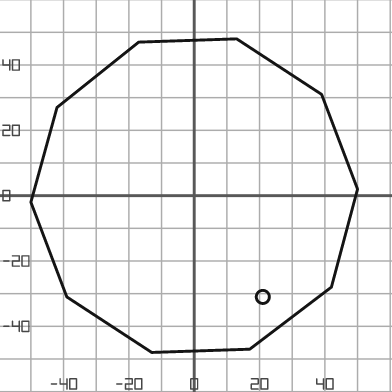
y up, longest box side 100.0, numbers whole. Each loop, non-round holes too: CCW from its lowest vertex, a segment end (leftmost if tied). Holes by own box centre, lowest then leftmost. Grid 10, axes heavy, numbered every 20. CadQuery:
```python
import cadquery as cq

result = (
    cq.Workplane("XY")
    .moveTo(-13.0, -48.0)
    .lineTo(17.0, -47.0)
    .lineTo(42.0, -28.0)
    .lineTo(50.0, 2.0)
    .lineTo(39.0, 31.0)
    .lineTo(13.0, 48.0)
    .lineTo(-17.0, 47.0)
    .lineTo(-42.0, 27.0)
    .lineTo(-50.0, -2.0)
    .lineTo(-39.0, -31.0)
    .close()
    .moveTo(21.0, -31.0)
    .circle(2.0)
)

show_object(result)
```